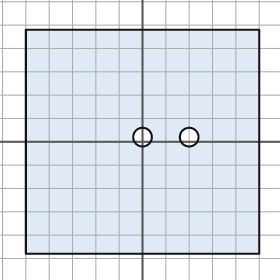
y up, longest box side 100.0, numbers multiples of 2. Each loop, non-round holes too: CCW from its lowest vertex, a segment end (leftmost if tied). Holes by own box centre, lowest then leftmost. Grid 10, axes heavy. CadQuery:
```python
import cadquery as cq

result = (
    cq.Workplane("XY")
    .moveTo(-50.0, -48.0)
    .lineTo(50.0, -48.0)
    .lineTo(50.0, 48.0)
    .lineTo(-50.0, 48.0)
    .close()
    .moveTo(0.0, 2.0)
    .circle(4.0)
    .moveTo(20.0, 2.0)
    .circle(4.0)
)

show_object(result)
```